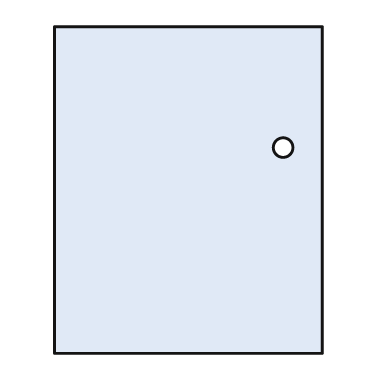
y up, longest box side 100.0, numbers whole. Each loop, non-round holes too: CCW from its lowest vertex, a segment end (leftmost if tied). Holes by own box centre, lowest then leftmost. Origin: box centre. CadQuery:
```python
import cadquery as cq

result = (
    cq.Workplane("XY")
    .moveTo(-41.0, -50.0)
    .lineTo(41.0, -50.0)
    .lineTo(41.0, 50.0)
    .lineTo(-41.0, 50.0)
    .close()
    .moveTo(29.0, 13.0)
    .circle(3.0)
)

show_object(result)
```